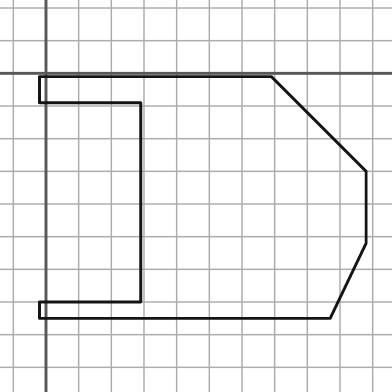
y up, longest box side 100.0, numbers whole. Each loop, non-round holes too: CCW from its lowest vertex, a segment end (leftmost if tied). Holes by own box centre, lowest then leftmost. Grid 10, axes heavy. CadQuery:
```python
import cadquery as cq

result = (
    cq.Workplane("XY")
    .moveTo(-2.0, -75.0)
    .lineTo(87.0, -75.0)
    .lineTo(98.0, -52.0)
    .lineTo(98.0, -30.0)
    .lineTo(69.0, -1.0)
    .lineTo(-2.0, -1.0)
    .lineTo(-2.0, -9.0)
    .lineTo(29.0, -9.0)
    .lineTo(29.0, -70.0)
    .lineTo(-2.0, -70.0)
    .close()
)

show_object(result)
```